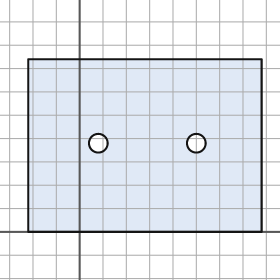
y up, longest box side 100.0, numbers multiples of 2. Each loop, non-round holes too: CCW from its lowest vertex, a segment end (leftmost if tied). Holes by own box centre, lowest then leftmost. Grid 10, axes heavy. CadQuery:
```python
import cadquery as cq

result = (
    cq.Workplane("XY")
    .moveTo(-22.0, 0.0)
    .lineTo(78.0, 0.0)
    .lineTo(78.0, 74.0)
    .lineTo(-22.0, 74.0)
    .close()
    .moveTo(8.0, 38.0)
    .circle(4.0)
    .moveTo(50.0, 38.0)
    .circle(4.0)
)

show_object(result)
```